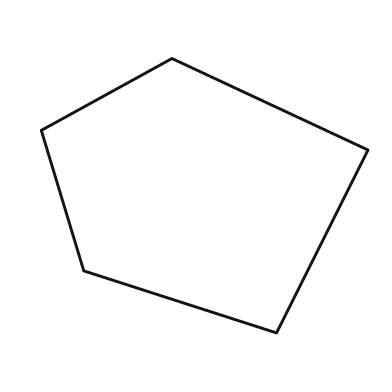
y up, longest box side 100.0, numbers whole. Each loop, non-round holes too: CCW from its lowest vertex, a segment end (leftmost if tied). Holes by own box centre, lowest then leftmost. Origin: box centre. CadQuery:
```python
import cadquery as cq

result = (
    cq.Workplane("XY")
    .moveTo(22.0, -42.0)
    .lineTo(50.0, 14.0)
    .lineTo(-10.0, 42.0)
    .lineTo(-50.0, 20.0)
    .lineTo(-37.0, -23.0)
    .close()
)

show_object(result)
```